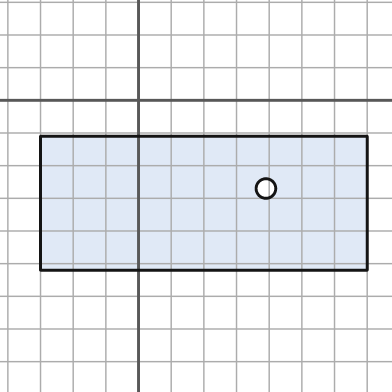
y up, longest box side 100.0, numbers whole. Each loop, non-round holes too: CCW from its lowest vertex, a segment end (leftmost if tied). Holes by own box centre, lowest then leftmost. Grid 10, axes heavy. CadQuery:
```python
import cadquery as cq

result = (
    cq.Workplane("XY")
    .moveTo(-30.0, -52.0)
    .lineTo(70.0, -52.0)
    .lineTo(70.0, -11.0)
    .lineTo(-30.0, -11.0)
    .close()
    .moveTo(39.0, -27.0)
    .circle(3.0)
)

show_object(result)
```